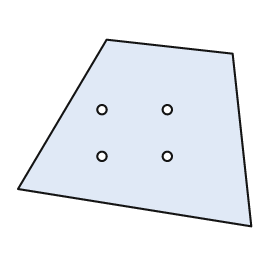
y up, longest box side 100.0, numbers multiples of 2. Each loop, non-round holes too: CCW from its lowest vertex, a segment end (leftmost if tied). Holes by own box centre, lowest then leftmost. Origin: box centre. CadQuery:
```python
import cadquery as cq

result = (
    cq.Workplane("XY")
    .moveTo(50.0, -40.0)
    .lineTo(42.0, 34.0)
    .lineTo(-12.0, 40.0)
    .lineTo(-50.0, -24.0)
    .close()
    .moveTo(-14.0, -10.0)
    .circle(2.0)
    .moveTo(14.0, -10.0)
    .circle(2.0)
    .moveTo(-14.0, 10.0)
    .circle(2.0)
    .moveTo(14.0, 10.0)
    .circle(2.0)
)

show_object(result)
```